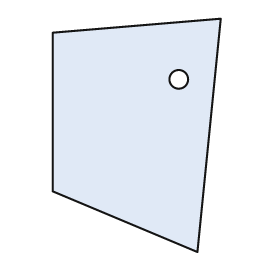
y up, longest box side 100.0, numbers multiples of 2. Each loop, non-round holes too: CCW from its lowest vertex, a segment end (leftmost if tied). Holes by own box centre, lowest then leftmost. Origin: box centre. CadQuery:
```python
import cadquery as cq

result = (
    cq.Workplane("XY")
    .moveTo(26.0, -50.0)
    .lineTo(36.0, 50.0)
    .lineTo(-36.0, 44.0)
    .lineTo(-36.0, -24.0)
    .close()
    .moveTo(18.0, 24.0)
    .circle(4.0)
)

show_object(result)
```